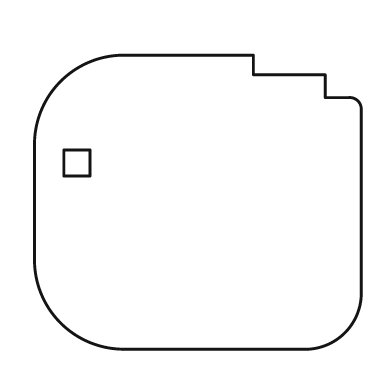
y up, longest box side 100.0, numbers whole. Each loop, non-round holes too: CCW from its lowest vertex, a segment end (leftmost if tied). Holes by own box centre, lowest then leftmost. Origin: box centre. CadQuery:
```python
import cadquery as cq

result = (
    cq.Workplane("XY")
    .moveTo(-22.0, -45.0)
    .lineTo(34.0, -45.0)
    .threePointArc((45.0, -40.0), (50.0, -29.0))
    .lineTo(50.0, 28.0)
    .threePointArc((49.0, 31.0), (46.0, 32.0))
    .lineTo(39.0, 32.0)
    .lineTo(39.0, 39.0)
    .lineTo(17.0, 39.0)
    .lineTo(17.0, 45.0)
    .lineTo(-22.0, 45.0)
    .threePointArc((-42.0, 37.0), (-50.0, 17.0))
    .lineTo(-50.0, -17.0)
    .threePointArc((-42.0, -37.0), (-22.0, -45.0))
    .close()
    .moveTo(-41.0, 8.0)
    .lineTo(-33.0, 8.0)
    .lineTo(-33.0, 16.0)
    .lineTo(-41.0, 16.0)
    .close()
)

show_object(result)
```